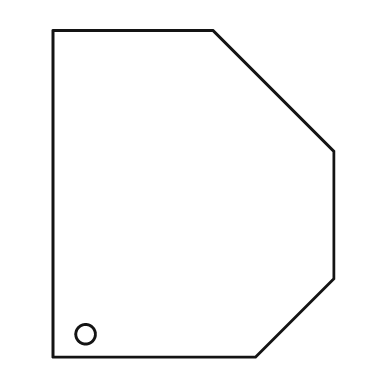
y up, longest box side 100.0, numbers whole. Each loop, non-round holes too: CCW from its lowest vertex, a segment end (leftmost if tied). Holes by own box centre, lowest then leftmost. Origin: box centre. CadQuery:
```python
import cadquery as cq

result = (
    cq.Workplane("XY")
    .moveTo(-43.0, -50.0)
    .lineTo(19.0, -50.0)
    .lineTo(43.0, -26.0)
    .lineTo(43.0, 13.0)
    .lineTo(6.0, 50.0)
    .lineTo(-43.0, 50.0)
    .close()
    .moveTo(-33.0, -43.0)
    .circle(3.0)
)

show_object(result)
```